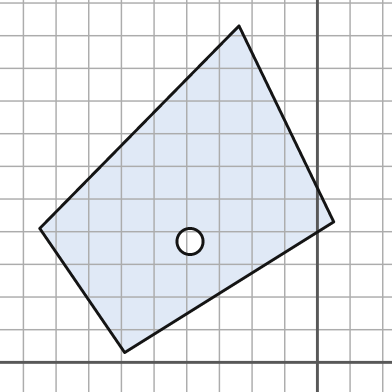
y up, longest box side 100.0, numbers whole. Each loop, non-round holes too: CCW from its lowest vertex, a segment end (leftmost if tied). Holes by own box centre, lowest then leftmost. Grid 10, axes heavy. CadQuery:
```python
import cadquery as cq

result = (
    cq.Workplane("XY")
    .moveTo(-59.0, 3.0)
    .lineTo(5.0, 43.0)
    .lineTo(-24.0, 103.0)
    .lineTo(-85.0, 41.0)
    .close()
    .moveTo(-39.0, 37.0)
    .circle(4.0)
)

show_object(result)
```